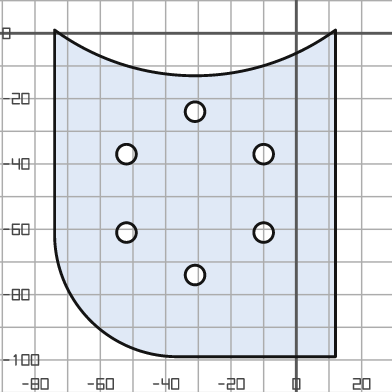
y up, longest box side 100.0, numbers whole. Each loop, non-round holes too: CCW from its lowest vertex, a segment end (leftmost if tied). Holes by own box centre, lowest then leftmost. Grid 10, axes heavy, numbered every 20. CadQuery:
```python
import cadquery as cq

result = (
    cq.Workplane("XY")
    .moveTo(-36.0, -99.0)
    .lineTo(12.0, -99.0)
    .lineTo(12.0, 1.0)
    .threePointArc((-31.0, -13.0), (-74.0, 1.0))
    .lineTo(-74.0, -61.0)
    .threePointArc((-63.0, -88.0), (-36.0, -99.0))
    .close()
    .moveTo(-31.0, -74.0)
    .circle(3.0)
    .moveTo(-52.0, -61.0)
    .circle(3.0)
    .moveTo(-10.0, -61.0)
    .circle(3.0)
    .moveTo(-52.0, -37.0)
    .circle(3.0)
    .moveTo(-10.0, -37.0)
    .circle(3.0)
    .moveTo(-31.0, -24.0)
    .circle(3.0)
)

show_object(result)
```